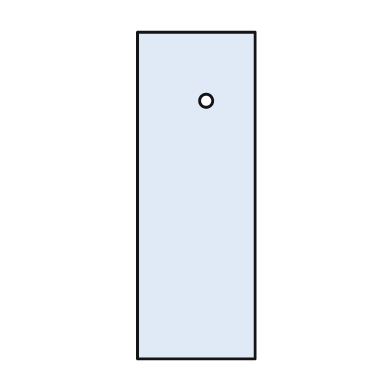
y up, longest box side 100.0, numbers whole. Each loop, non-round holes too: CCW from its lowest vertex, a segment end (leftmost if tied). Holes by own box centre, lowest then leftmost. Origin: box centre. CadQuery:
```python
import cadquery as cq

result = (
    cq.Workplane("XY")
    .moveTo(-18.0, -50.0)
    .lineTo(18.0, -50.0)
    .lineTo(18.0, 50.0)
    .lineTo(-18.0, 50.0)
    .close()
    .moveTo(3.0, 29.0)
    .circle(2.0)
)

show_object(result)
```